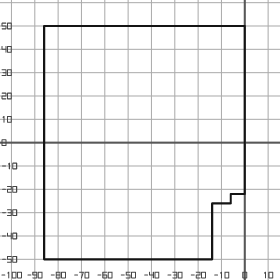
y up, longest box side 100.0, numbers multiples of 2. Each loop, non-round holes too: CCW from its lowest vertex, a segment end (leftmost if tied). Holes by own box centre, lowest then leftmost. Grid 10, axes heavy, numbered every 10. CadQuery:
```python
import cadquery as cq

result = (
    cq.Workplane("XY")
    .moveTo(-86.0, -50.0)
    .lineTo(-14.0, -50.0)
    .lineTo(-14.0, -26.0)
    .lineTo(-6.0, -26.0)
    .lineTo(-6.0, -22.0)
    .lineTo(0.0, -22.0)
    .lineTo(0.0, 50.0)
    .lineTo(-86.0, 50.0)
    .close()
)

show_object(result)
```